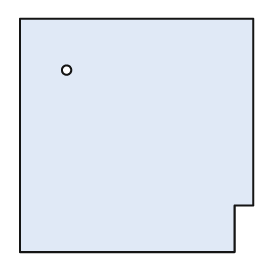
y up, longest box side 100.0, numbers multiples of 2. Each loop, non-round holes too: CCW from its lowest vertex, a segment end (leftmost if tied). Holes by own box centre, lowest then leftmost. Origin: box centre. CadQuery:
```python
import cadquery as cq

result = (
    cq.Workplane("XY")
    .moveTo(-50.0, -50.0)
    .lineTo(42.0, -50.0)
    .lineTo(42.0, -30.0)
    .lineTo(50.0, -30.0)
    .lineTo(50.0, 50.0)
    .lineTo(-50.0, 50.0)
    .close()
    .moveTo(-30.0, 28.0)
    .circle(2.0)
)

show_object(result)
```